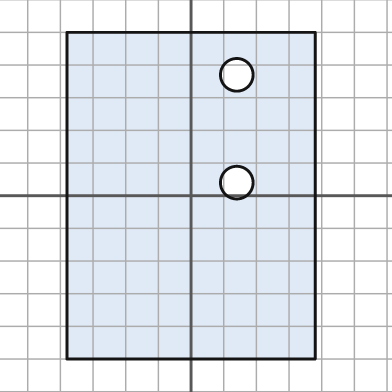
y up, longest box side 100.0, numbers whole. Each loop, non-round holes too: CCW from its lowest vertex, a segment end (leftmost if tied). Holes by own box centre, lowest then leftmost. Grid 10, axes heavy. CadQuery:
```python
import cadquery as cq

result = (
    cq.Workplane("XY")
    .moveTo(-38.0, -50.0)
    .lineTo(38.0, -50.0)
    .lineTo(38.0, 50.0)
    .lineTo(-38.0, 50.0)
    .close()
    .moveTo(14.0, 4.0)
    .circle(5.0)
    .moveTo(14.0, 37.0)
    .circle(5.0)
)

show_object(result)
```